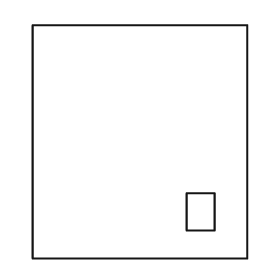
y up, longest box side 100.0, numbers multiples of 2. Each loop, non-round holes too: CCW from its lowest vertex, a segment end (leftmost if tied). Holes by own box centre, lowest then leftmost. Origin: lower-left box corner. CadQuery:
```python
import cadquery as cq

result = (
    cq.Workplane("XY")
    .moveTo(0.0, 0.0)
    .lineTo(92.0, 0.0)
    .lineTo(92.0, 100.0)
    .lineTo(0.0, 100.0)
    .close()
    .moveTo(66.0, 12.0)
    .lineTo(78.0, 12.0)
    .lineTo(78.0, 28.0)
    .lineTo(66.0, 28.0)
    .close()
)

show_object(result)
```